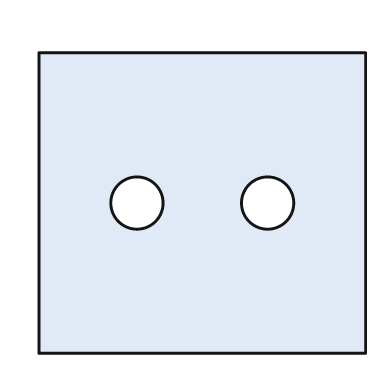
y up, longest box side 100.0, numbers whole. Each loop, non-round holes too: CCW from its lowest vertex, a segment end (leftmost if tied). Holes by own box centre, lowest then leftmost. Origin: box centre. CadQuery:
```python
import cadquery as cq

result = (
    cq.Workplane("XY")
    .moveTo(-50.0, -46.0)
    .lineTo(50.0, -46.0)
    .lineTo(50.0, 46.0)
    .lineTo(-50.0, 46.0)
    .close()
    .moveTo(-20.0, 0.0)
    .circle(8.0)
    .moveTo(20.0, 0.0)
    .circle(8.0)
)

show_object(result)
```